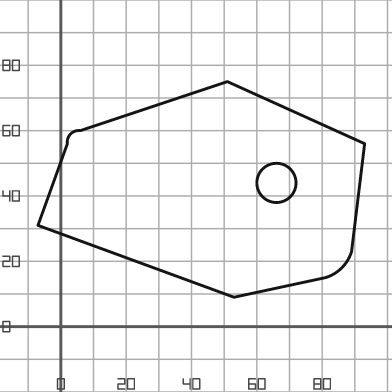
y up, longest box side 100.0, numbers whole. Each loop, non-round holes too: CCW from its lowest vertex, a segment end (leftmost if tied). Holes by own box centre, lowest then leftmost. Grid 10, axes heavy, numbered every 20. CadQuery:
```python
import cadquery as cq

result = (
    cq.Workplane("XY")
    .moveTo(53.0, 9.0)
    .lineTo(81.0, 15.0)
    .threePointArc((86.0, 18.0), (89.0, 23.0))
    .lineTo(93.0, 56.0)
    .lineTo(51.0, 75.0)
    .lineTo(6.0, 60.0)
    .threePointArc((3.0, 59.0), (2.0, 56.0))
    .lineTo(-7.0, 31.0)
    .close()
    .moveTo(66.0, 44.0)
    .circle(6.0)
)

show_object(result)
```